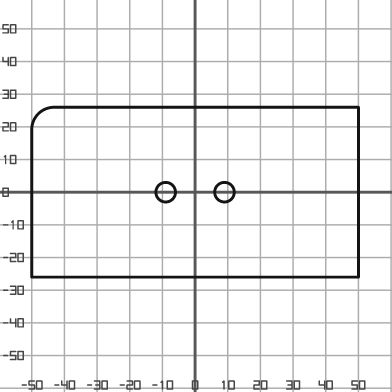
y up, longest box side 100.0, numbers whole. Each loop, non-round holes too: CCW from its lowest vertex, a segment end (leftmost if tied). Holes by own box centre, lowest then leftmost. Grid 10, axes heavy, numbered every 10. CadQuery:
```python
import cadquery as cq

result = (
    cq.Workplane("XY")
    .moveTo(-50.0, -26.0)
    .lineTo(50.0, -26.0)
    .lineTo(50.0, 26.0)
    .lineTo(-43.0, 26.0)
    .threePointArc((-48.0, 24.0), (-50.0, 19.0))
    .close()
    .moveTo(-9.0, 0.0)
    .circle(3.0)
    .moveTo(9.0, 0.0)
    .circle(3.0)
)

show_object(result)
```